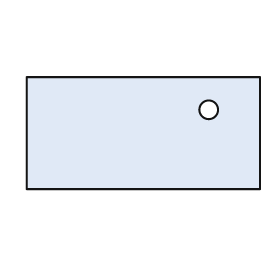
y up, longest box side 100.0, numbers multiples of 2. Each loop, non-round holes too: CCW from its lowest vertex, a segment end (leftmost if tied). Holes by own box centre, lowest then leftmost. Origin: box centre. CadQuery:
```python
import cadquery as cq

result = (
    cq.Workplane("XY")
    .moveTo(-50.0, -24.0)
    .lineTo(50.0, -24.0)
    .lineTo(50.0, 24.0)
    .lineTo(-50.0, 24.0)
    .close()
    .moveTo(28.0, 10.0)
    .circle(4.0)
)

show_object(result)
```